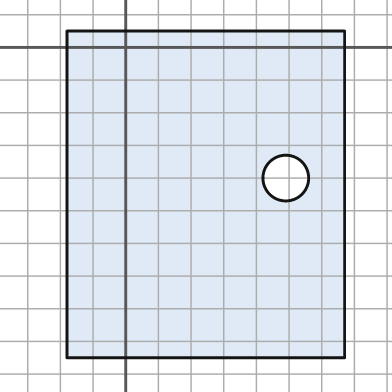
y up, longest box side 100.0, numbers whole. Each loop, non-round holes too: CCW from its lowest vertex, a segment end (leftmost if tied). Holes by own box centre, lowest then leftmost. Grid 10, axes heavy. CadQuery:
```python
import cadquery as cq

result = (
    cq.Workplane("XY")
    .moveTo(-18.0, -95.0)
    .lineTo(67.0, -95.0)
    .lineTo(67.0, 5.0)
    .lineTo(-18.0, 5.0)
    .close()
    .moveTo(49.0, -40.0)
    .circle(7.0)
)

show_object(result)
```